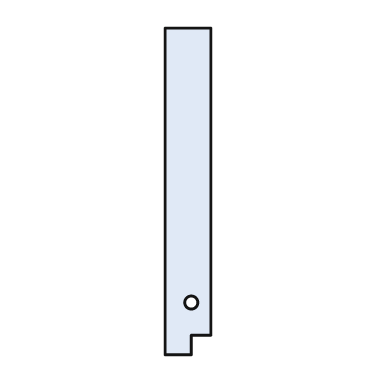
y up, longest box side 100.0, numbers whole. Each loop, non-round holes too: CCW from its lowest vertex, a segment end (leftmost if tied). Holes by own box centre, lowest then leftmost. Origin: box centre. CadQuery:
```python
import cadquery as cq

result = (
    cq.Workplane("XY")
    .moveTo(-7.0, -50.0)
    .lineTo(1.0, -50.0)
    .lineTo(1.0, -44.0)
    .lineTo(7.0, -44.0)
    .lineTo(7.0, 50.0)
    .lineTo(-7.0, 50.0)
    .close()
    .moveTo(1.0, -34.0)
    .circle(2.0)
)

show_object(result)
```